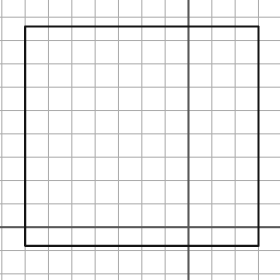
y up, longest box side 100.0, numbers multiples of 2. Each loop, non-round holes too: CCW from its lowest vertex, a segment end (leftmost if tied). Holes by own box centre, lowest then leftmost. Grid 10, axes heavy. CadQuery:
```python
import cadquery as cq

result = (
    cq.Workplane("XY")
    .moveTo(-70.0, -8.0)
    .lineTo(30.0, -8.0)
    .lineTo(30.0, 86.0)
    .lineTo(-70.0, 86.0)
    .close()
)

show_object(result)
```